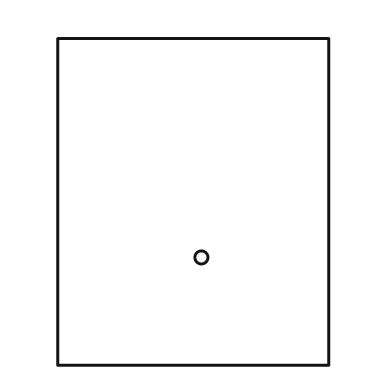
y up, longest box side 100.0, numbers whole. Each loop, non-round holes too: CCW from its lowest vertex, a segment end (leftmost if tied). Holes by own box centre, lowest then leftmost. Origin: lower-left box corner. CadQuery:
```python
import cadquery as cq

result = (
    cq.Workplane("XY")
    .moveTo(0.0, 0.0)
    .lineTo(83.0, 0.0)
    .lineTo(83.0, 100.0)
    .lineTo(0.0, 100.0)
    .close()
    .moveTo(44.0, 33.0)
    .circle(2.0)
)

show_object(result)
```